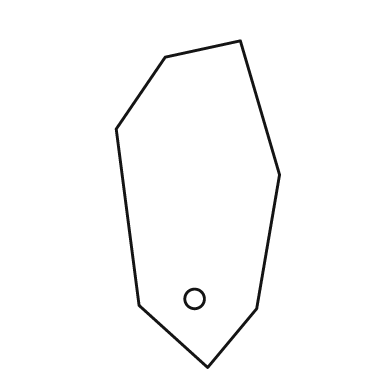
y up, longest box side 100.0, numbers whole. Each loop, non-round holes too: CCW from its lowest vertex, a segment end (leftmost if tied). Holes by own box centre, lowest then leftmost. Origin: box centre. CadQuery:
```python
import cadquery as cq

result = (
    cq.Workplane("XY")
    .moveTo(3.0, -50.0)
    .lineTo(18.0, -32.0)
    .lineTo(25.0, 9.0)
    .lineTo(13.0, 50.0)
    .lineTo(-10.0, 45.0)
    .lineTo(-25.0, 23.0)
    .lineTo(-18.0, -31.0)
    .close()
    .moveTo(-1.0, -29.0)
    .circle(3.0)
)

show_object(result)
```